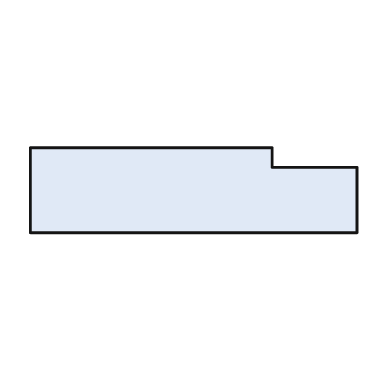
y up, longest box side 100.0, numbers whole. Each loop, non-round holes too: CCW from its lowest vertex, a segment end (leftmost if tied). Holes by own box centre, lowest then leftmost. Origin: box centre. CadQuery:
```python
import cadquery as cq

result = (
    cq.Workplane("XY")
    .moveTo(-50.0, -13.0)
    .lineTo(50.0, -13.0)
    .lineTo(50.0, 7.0)
    .lineTo(24.0, 7.0)
    .lineTo(24.0, 13.0)
    .lineTo(-50.0, 13.0)
    .close()
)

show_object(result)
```